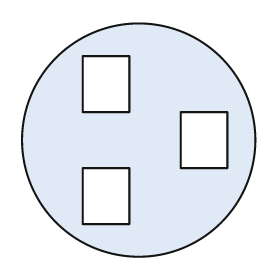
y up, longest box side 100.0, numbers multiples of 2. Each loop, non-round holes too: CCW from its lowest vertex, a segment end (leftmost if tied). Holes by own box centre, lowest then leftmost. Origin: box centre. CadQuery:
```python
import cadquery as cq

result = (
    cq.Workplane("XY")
    .moveTo(0.0, 0.0)
    .circle(50.0)
    .moveTo(-24.0, -36.0)
    .lineTo(-4.0, -36.0)
    .lineTo(-4.0, -12.0)
    .lineTo(-24.0, -12.0)
    .close()
    .moveTo(18.0, -12.0)
    .lineTo(38.0, -12.0)
    .lineTo(38.0, 12.0)
    .lineTo(18.0, 12.0)
    .close()
    .moveTo(-24.0, 12.0)
    .lineTo(-4.0, 12.0)
    .lineTo(-4.0, 36.0)
    .lineTo(-24.0, 36.0)
    .close()
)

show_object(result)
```